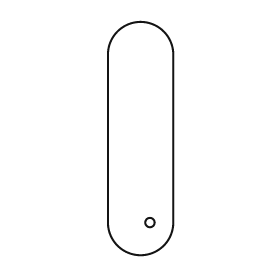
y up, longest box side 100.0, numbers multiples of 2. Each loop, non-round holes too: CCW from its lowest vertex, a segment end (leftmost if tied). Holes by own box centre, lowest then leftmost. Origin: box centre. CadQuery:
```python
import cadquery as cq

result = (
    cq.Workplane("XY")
    .moveTo(-14.0, -36.0)
    .threePointArc((0.0, -50.0), (14.0, -36.0))
    .lineTo(14.0, 36.0)
    .threePointArc((0.0, 50.0), (-14.0, 36.0))
    .close()
    .moveTo(4.0, -36.0)
    .circle(2.0)
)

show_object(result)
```